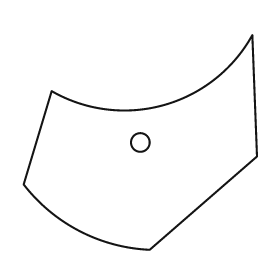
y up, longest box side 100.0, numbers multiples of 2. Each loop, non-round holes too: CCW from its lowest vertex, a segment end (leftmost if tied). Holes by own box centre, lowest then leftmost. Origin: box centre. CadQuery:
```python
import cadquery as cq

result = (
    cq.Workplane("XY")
    .moveTo(4.0, -46.0)
    .lineTo(50.0, -6.0)
    .lineTo(48.0, 46.0)
    .threePointArc((10.0, 16.0), (-38.0, 22.0))
    .lineTo(-50.0, -18.0)
    .threePointArc((-26.0, -38.0), (4.0, -46.0))
    .close()
    .moveTo(0.0, 0.0)
    .circle(4.0)
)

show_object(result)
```